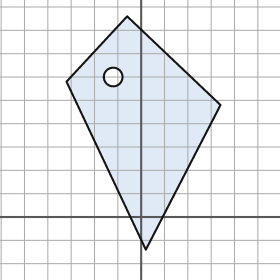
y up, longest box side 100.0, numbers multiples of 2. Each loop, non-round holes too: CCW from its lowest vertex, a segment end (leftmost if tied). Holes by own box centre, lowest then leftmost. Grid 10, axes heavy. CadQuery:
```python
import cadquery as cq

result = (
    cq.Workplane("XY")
    .moveTo(2.0, -14.0)
    .lineTo(34.0, 48.0)
    .lineTo(-6.0, 86.0)
    .lineTo(-32.0, 58.0)
    .close()
    .moveTo(-12.0, 60.0)
    .circle(4.0)
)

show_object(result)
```